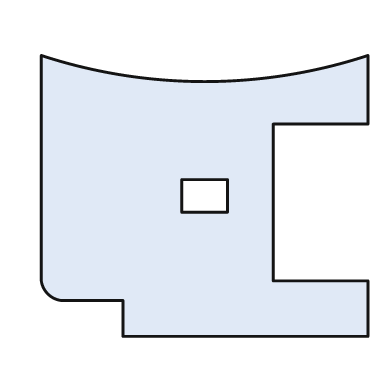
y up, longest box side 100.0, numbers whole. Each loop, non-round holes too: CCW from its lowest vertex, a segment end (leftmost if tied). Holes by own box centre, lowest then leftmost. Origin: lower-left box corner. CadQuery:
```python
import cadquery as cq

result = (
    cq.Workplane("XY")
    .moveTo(25.0, 0.0)
    .lineTo(100.0, 0.0)
    .lineTo(100.0, 17.0)
    .lineTo(71.0, 17.0)
    .lineTo(71.0, 65.0)
    .lineTo(100.0, 65.0)
    .lineTo(100.0, 86.0)
    .threePointArc((50.0, 78.0), (0.0, 86.0))
    .lineTo(0.0, 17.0)
    .threePointArc((2.0, 13.0), (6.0, 11.0))
    .lineTo(25.0, 11.0)
    .close()
    .moveTo(43.0, 38.0)
    .lineTo(57.0, 38.0)
    .lineTo(57.0, 48.0)
    .lineTo(43.0, 48.0)
    .close()
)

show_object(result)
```